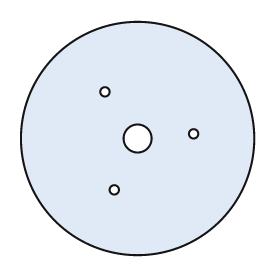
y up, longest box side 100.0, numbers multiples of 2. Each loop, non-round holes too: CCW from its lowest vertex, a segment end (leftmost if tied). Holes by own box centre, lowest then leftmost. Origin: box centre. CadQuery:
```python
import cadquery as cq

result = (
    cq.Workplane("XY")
    .moveTo(0.0, 0.0)
    .circle(50.0)
    .moveTo(-10.0, -22.0)
    .circle(2.0)
    .moveTo(0.0, 0.0)
    .circle(6.0)
    .moveTo(24.0, 2.0)
    .circle(2.0)
    .moveTo(-14.0, 20.0)
    .circle(2.0)
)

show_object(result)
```